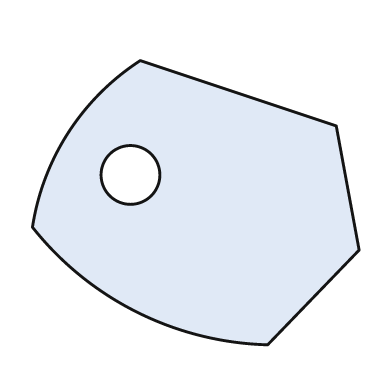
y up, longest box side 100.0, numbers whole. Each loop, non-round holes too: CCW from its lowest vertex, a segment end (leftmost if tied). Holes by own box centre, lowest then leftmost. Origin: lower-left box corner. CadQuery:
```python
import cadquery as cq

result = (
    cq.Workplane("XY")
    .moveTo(72.0, 0.0)
    .lineTo(100.0, 29.0)
    .lineTo(93.0, 67.0)
    .lineTo(33.0, 87.0)
    .threePointArc((11.0, 65.0), (0.0, 36.0))
    .threePointArc((32.0, 10.0), (72.0, 0.0))
    .close()
    .moveTo(30.0, 52.0)
    .circle(9.0)
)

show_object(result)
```